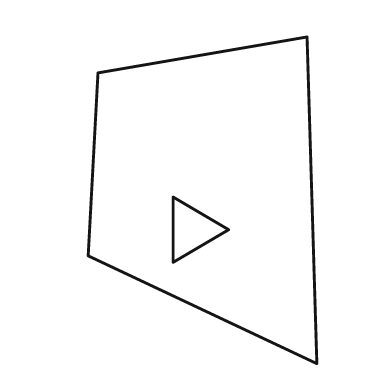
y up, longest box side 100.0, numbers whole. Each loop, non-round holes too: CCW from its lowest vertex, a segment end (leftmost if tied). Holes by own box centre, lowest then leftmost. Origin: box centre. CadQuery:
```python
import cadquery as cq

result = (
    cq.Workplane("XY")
    .moveTo(35.0, -50.0)
    .lineTo(32.0, 50.0)
    .lineTo(-32.0, 39.0)
    .lineTo(-35.0, -17.0)
    .close()
    .moveTo(-9.0, -19.0)
    .lineTo(8.0, -9.0)
    .lineTo(-9.0, 1.0)
    .close()
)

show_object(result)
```